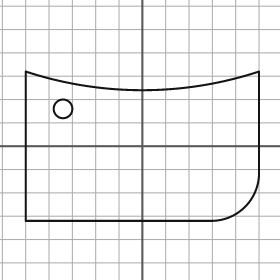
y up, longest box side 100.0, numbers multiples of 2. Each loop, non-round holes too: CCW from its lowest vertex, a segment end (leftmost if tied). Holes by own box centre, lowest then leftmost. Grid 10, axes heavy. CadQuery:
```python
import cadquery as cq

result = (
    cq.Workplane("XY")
    .moveTo(-50.0, -32.0)
    .lineTo(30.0, -32.0)
    .threePointArc((44.0, -26.0), (50.0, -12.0))
    .lineTo(50.0, 32.0)
    .threePointArc((0.0, 24.0), (-50.0, 32.0))
    .close()
    .moveTo(-34.0, 16.0)
    .circle(4.0)
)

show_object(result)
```